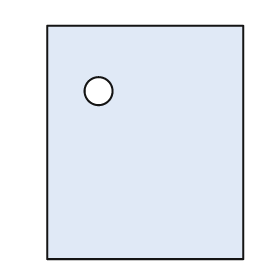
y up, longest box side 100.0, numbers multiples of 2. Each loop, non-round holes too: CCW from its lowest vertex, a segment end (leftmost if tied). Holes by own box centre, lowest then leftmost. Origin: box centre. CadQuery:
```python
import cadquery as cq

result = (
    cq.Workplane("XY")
    .moveTo(-42.0, -50.0)
    .lineTo(42.0, -50.0)
    .lineTo(42.0, 50.0)
    .lineTo(-42.0, 50.0)
    .close()
    .moveTo(-20.0, 22.0)
    .circle(6.0)
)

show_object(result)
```